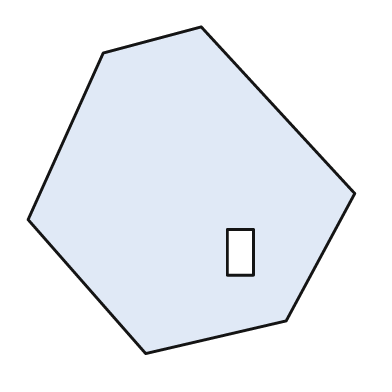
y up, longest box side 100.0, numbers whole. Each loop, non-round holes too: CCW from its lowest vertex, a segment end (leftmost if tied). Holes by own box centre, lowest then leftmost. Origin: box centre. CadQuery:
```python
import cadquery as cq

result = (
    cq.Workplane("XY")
    .moveTo(-14.0, -50.0)
    .lineTo(29.0, -40.0)
    .lineTo(50.0, -1.0)
    .lineTo(3.0, 50.0)
    .lineTo(-27.0, 42.0)
    .lineTo(-50.0, -9.0)
    .close()
    .moveTo(11.0, -26.0)
    .lineTo(19.0, -26.0)
    .lineTo(19.0, -12.0)
    .lineTo(11.0, -12.0)
    .close()
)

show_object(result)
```